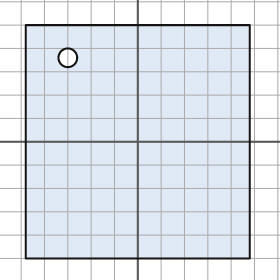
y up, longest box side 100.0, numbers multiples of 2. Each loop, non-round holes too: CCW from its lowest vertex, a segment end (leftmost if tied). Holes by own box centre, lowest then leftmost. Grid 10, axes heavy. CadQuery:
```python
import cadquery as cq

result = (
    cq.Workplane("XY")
    .moveTo(-48.0, -50.0)
    .lineTo(48.0, -50.0)
    .lineTo(48.0, 50.0)
    .lineTo(-48.0, 50.0)
    .close()
    .moveTo(-30.0, 36.0)
    .circle(4.0)
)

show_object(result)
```